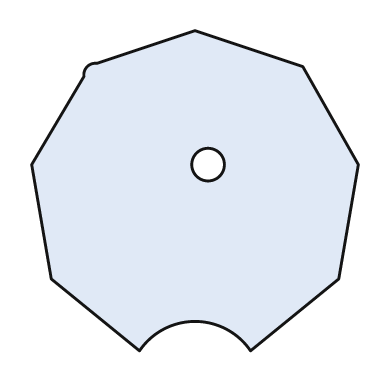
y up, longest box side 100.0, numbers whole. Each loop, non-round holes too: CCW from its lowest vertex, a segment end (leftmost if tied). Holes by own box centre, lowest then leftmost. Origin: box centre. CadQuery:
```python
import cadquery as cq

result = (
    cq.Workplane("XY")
    .moveTo(-17.0, -49.0)
    .threePointArc((0.0, -40.0), (17.0, -49.0))
    .lineTo(44.0, -27.0)
    .lineTo(50.0, 8.0)
    .lineTo(33.0, 38.0)
    .lineTo(0.0, 49.0)
    .lineTo(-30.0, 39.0)
    .threePointArc((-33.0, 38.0), (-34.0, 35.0))
    .lineTo(-50.0, 8.0)
    .lineTo(-44.0, -27.0)
    .close()
    .moveTo(4.0, 8.0)
    .circle(5.0)
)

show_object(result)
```